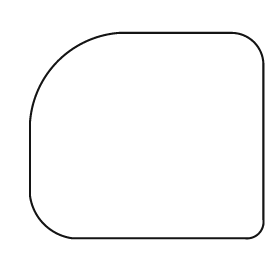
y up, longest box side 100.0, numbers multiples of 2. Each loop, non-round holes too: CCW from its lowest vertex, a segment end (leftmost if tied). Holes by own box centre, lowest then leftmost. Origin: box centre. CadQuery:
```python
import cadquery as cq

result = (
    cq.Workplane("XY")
    .moveTo(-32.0, -44.0)
    .lineTo(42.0, -44.0)
    .threePointArc((48.0, -42.0), (50.0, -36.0))
    .lineTo(50.0, 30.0)
    .threePointArc((46.0, 40.0), (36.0, 44.0))
    .lineTo(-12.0, 44.0)
    .threePointArc((-38.0, 32.0), (-50.0, 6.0))
    .lineTo(-50.0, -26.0)
    .threePointArc((-44.0, -38.0), (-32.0, -44.0))
    .close()
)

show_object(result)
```